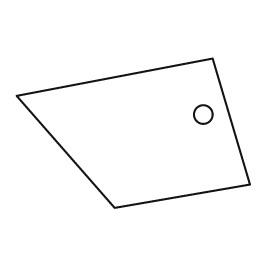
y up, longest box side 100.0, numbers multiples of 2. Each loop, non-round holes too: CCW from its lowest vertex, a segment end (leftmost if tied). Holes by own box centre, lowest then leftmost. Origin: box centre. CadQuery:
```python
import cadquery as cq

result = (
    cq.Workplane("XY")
    .moveTo(-8.0, -32.0)
    .lineTo(50.0, -22.0)
    .lineTo(34.0, 32.0)
    .lineTo(-50.0, 16.0)
    .close()
    .moveTo(30.0, 8.0)
    .circle(4.0)
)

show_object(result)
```